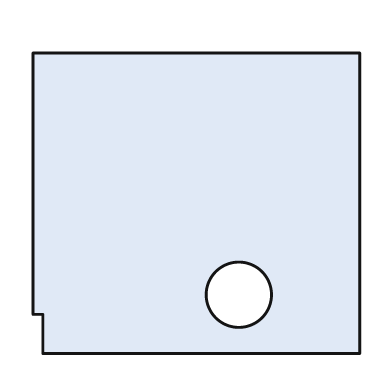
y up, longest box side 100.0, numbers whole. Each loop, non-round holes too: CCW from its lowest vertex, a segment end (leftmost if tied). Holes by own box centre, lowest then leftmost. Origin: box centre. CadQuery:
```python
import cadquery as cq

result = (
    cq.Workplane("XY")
    .moveTo(-47.0, -46.0)
    .lineTo(50.0, -46.0)
    .lineTo(50.0, 46.0)
    .lineTo(-50.0, 46.0)
    .lineTo(-50.0, -34.0)
    .lineTo(-47.0, -34.0)
    .close()
    .moveTo(13.0, -28.0)
    .circle(10.0)
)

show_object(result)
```